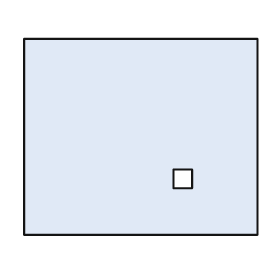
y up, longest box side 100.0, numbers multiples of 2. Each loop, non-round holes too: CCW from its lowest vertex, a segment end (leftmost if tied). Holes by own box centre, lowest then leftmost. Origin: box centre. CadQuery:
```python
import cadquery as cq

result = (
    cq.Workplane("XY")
    .moveTo(-50.0, -42.0)
    .lineTo(50.0, -42.0)
    .lineTo(50.0, 42.0)
    .lineTo(-50.0, 42.0)
    .close()
    .moveTo(14.0, -22.0)
    .lineTo(22.0, -22.0)
    .lineTo(22.0, -14.0)
    .lineTo(14.0, -14.0)
    .close()
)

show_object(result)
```